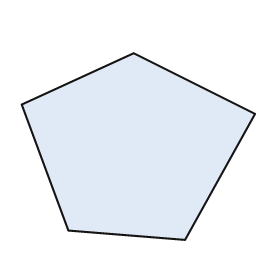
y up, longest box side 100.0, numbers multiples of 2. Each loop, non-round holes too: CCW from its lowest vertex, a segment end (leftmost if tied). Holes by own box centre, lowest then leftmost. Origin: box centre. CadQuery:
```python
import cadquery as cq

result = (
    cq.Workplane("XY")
    .moveTo(20.0, -40.0)
    .lineTo(50.0, 14.0)
    .lineTo(-2.0, 40.0)
    .lineTo(-50.0, 18.0)
    .lineTo(-30.0, -36.0)
    .close()
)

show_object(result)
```